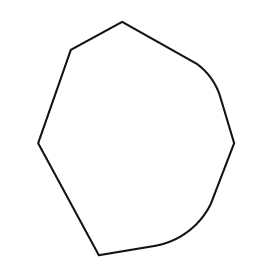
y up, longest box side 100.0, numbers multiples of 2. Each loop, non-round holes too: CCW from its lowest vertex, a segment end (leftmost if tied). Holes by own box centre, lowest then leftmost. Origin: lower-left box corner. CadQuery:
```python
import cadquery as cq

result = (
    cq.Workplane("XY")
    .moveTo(26.0, 0.0)
    .lineTo(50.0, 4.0)
    .threePointArc((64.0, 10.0), (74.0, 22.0))
    .lineTo(84.0, 48.0)
    .lineTo(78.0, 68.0)
    .threePointArc((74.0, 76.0), (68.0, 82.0))
    .lineTo(36.0, 100.0)
    .lineTo(14.0, 88.0)
    .lineTo(0.0, 48.0)
    .close()
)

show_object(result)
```